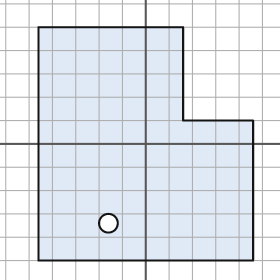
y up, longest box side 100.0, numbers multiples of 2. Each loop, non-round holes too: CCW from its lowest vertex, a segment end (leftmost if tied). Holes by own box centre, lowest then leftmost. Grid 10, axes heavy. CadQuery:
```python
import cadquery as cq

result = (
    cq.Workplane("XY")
    .moveTo(-46.0, -50.0)
    .lineTo(46.0, -50.0)
    .lineTo(46.0, 10.0)
    .lineTo(16.0, 10.0)
    .lineTo(16.0, 50.0)
    .lineTo(-46.0, 50.0)
    .close()
    .moveTo(-16.0, -34.0)
    .circle(4.0)
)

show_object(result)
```